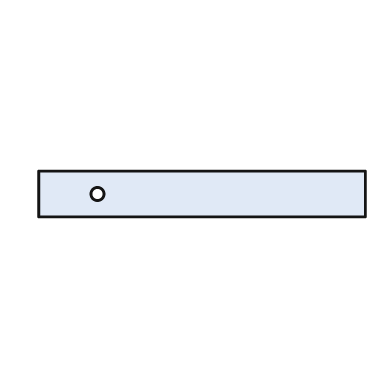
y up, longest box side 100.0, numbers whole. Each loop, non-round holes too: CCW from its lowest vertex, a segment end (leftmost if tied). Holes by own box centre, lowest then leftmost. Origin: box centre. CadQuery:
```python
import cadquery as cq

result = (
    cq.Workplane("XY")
    .moveTo(-50.0, -7.0)
    .lineTo(50.0, -7.0)
    .lineTo(50.0, 7.0)
    .lineTo(-50.0, 7.0)
    .close()
    .moveTo(-32.0, 0.0)
    .circle(2.0)
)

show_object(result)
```